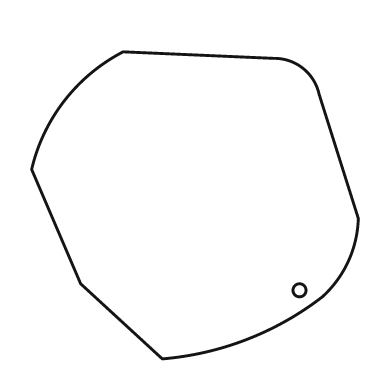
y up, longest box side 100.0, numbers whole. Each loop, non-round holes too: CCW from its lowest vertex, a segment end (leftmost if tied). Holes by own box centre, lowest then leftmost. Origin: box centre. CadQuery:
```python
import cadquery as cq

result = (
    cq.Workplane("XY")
    .moveTo(-10.0, -47.0)
    .threePointArc((16.0, -41.0), (39.0, -28.0))
    .threePointArc((47.0, -17.0), (50.0, -4.0))
    .lineTo(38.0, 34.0)
    .threePointArc((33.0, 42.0), (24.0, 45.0))
    .lineTo(-22.0, 47.0)
    .threePointArc((-40.0, 32.0), (-50.0, 11.0))
    .lineTo(-35.0, -24.0)
    .close()
    .moveTo(32.0, -26.0)
    .circle(2.0)
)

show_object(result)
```